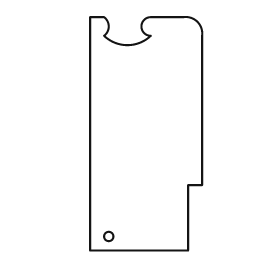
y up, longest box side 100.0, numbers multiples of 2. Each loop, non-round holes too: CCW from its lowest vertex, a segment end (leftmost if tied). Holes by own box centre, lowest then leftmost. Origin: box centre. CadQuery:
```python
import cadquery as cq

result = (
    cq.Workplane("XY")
    .moveTo(-24.0, -50.0)
    .lineTo(18.0, -50.0)
    .lineTo(18.0, -22.0)
    .lineTo(24.0, -22.0)
    .lineTo(24.0, 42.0)
    .threePointArc((22.0, 48.0), (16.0, 50.0))
    .lineTo(2.0, 50.0)
    .threePointArc((-2.0, 46.0), (2.0, 42.0))
    .threePointArc((-8.0, 38.0), (-18.0, 42.0))
    .threePointArc((-16.0, 46.0), (-18.0, 50.0))
    .lineTo(-24.0, 50.0)
    .close()
    .moveTo(-16.0, -44.0)
    .circle(2.0)
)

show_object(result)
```